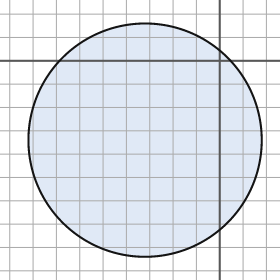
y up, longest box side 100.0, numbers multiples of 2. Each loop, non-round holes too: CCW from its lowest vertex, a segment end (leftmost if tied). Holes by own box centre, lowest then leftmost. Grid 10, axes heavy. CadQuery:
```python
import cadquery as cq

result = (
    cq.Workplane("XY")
    .moveTo(-32.0, -34.0)
    .circle(50.0)
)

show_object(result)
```